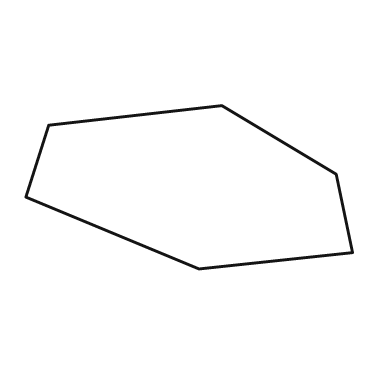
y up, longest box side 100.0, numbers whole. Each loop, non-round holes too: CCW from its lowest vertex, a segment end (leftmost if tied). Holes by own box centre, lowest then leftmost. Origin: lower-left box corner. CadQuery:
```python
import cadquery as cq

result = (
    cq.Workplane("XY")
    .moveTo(53.0, 0.0)
    .lineTo(100.0, 5.0)
    .lineTo(95.0, 29.0)
    .lineTo(60.0, 50.0)
    .lineTo(7.0, 44.0)
    .lineTo(0.0, 22.0)
    .close()
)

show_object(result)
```